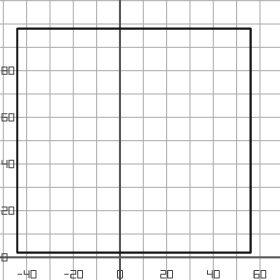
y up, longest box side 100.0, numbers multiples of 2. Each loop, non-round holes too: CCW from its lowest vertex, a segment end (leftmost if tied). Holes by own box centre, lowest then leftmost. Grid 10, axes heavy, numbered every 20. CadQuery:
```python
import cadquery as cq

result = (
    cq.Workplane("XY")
    .moveTo(-44.0, 2.0)
    .lineTo(56.0, 2.0)
    .lineTo(56.0, 98.0)
    .lineTo(-44.0, 98.0)
    .close()
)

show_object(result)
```